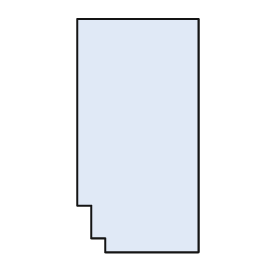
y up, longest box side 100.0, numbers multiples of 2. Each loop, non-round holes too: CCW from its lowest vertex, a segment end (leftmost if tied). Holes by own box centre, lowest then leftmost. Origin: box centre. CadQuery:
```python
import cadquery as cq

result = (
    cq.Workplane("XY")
    .moveTo(-14.0, -50.0)
    .lineTo(26.0, -50.0)
    .lineTo(26.0, 50.0)
    .lineTo(-26.0, 50.0)
    .lineTo(-26.0, -30.0)
    .lineTo(-20.0, -30.0)
    .lineTo(-20.0, -44.0)
    .lineTo(-14.0, -44.0)
    .close()
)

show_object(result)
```